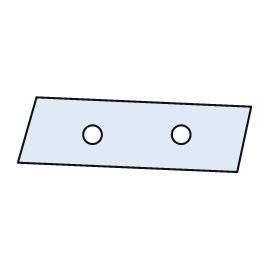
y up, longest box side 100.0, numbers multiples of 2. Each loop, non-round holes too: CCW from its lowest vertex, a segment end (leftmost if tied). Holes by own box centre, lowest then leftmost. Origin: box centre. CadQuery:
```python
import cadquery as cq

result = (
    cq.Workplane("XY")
    .moveTo(44.0, -16.0)
    .lineTo(50.0, 12.0)
    .lineTo(-42.0, 16.0)
    .lineTo(-50.0, -12.0)
    .close()
    .moveTo(-18.0, 0.0)
    .circle(4.0)
    .moveTo(20.0, 0.0)
    .circle(4.0)
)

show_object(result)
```